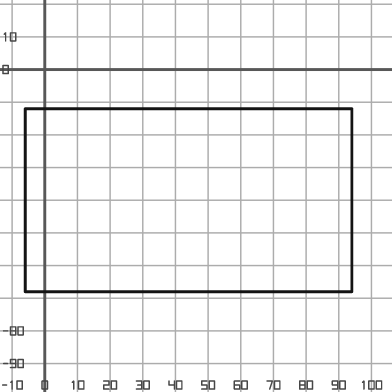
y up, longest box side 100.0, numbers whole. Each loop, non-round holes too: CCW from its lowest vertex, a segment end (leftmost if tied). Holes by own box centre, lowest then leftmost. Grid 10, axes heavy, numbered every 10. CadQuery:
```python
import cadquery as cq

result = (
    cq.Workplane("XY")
    .moveTo(-6.0, -68.0)
    .lineTo(94.0, -68.0)
    .lineTo(94.0, -12.0)
    .lineTo(-6.0, -12.0)
    .close()
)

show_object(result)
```